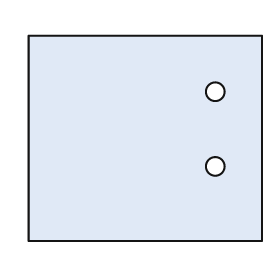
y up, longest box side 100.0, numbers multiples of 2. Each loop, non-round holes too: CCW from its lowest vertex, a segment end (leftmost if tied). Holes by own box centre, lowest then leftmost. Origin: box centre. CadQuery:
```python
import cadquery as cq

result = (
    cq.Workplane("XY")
    .moveTo(-50.0, -44.0)
    .lineTo(50.0, -44.0)
    .lineTo(50.0, 44.0)
    .lineTo(-50.0, 44.0)
    .close()
    .moveTo(30.0, -12.0)
    .circle(4.0)
    .moveTo(30.0, 20.0)
    .circle(4.0)
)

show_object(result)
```